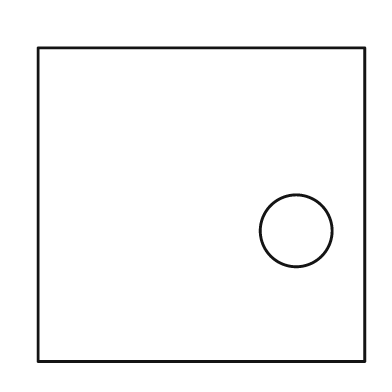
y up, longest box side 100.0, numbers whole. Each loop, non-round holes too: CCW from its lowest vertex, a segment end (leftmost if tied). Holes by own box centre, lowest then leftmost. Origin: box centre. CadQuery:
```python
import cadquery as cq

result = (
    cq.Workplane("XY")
    .moveTo(-50.0, -48.0)
    .lineTo(50.0, -48.0)
    .lineTo(50.0, 48.0)
    .lineTo(-50.0, 48.0)
    .close()
    .moveTo(29.0, -8.0)
    .circle(11.0)
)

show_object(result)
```